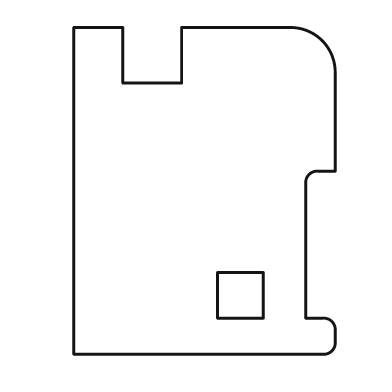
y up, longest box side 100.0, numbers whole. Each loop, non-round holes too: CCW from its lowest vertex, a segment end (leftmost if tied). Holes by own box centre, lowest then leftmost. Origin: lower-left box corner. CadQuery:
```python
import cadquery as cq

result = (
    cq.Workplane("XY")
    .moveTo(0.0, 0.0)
    .lineTo(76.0, 0.0)
    .threePointArc((79.0, 1.0), (80.0, 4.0))
    .lineTo(80.0, 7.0)
    .threePointArc((79.0, 10.0), (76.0, 11.0))
    .lineTo(71.0, 11.0)
    .lineTo(71.0, 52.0)
    .threePointArc((72.0, 55.0), (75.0, 56.0))
    .lineTo(80.0, 56.0)
    .lineTo(80.0, 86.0)
    .threePointArc((76.0, 96.0), (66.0, 100.0))
    .lineTo(33.0, 100.0)
    .lineTo(33.0, 83.0)
    .lineTo(15.0, 83.0)
    .lineTo(15.0, 100.0)
    .lineTo(0.0, 100.0)
    .close()
    .moveTo(44.0, 11.0)
    .lineTo(58.0, 11.0)
    .lineTo(58.0, 25.0)
    .lineTo(44.0, 25.0)
    .close()
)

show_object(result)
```